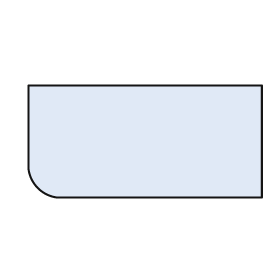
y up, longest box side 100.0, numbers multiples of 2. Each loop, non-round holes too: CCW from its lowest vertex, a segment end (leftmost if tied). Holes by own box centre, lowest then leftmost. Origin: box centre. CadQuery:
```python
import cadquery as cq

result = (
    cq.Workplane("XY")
    .moveTo(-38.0, -24.0)
    .lineTo(50.0, -24.0)
    .lineTo(50.0, 24.0)
    .lineTo(-50.0, 24.0)
    .lineTo(-50.0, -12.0)
    .threePointArc((-46.0, -20.0), (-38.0, -24.0))
    .close()
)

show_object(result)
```